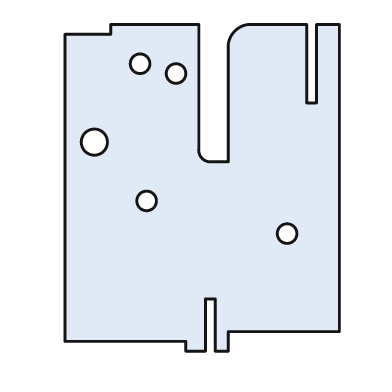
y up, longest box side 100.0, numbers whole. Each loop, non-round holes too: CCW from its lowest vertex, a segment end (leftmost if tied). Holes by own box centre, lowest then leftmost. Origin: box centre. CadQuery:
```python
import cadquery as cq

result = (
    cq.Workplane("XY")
    .moveTo(-5.0, -50.0)
    .lineTo(1.0, -50.0)
    .lineTo(1.0, -34.0)
    .lineTo(4.0, -34.0)
    .lineTo(4.0, -50.0)
    .lineTo(8.0, -50.0)
    .lineTo(8.0, -44.0)
    .lineTo(42.0, -44.0)
    .lineTo(42.0, 50.0)
    .lineTo(35.0, 50.0)
    .lineTo(35.0, 26.0)
    .lineTo(32.0, 26.0)
    .lineTo(32.0, 50.0)
    .lineTo(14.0, 50.0)
    .threePointArc((10.0, 48.0), (8.0, 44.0))
    .lineTo(8.0, 8.0)
    .lineTo(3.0, 8.0)
    .threePointArc((0.0, 9.0), (-1.0, 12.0))
    .lineTo(-1.0, 50.0)
    .lineTo(-28.0, 50.0)
    .lineTo(-28.0, 47.0)
    .lineTo(-42.0, 47.0)
    .lineTo(-42.0, -47.0)
    .lineTo(-5.0, -47.0)
    .close()
    .moveTo(26.0, -14.0)
    .circle(3.0)
    .moveTo(-17.0, -4.0)
    .circle(3.0)
    .moveTo(-33.0, 14.0)
    .circle(4.0)
    .moveTo(-8.0, 35.0)
    .circle(3.0)
    .moveTo(-19.0, 38.0)
    .circle(3.0)
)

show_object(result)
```